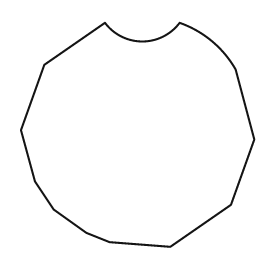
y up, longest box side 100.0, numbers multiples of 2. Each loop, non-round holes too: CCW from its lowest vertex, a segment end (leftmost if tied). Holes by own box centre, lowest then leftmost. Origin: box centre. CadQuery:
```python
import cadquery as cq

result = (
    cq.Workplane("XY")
    .moveTo(14.0, -48.0)
    .lineTo(40.0, -30.0)
    .lineTo(50.0, -2.0)
    .lineTo(42.0, 28.0)
    .threePointArc((32.0, 40.0), (18.0, 48.0))
    .threePointArc((2.0, 40.0), (-14.0, 48.0))
    .lineTo(-40.0, 30.0)
    .lineTo(-50.0, 2.0)
    .lineTo(-44.0, -20.0)
    .lineTo(-36.0, -32.0)
    .lineTo(-22.0, -42.0)
    .lineTo(-12.0, -46.0)
    .close()
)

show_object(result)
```